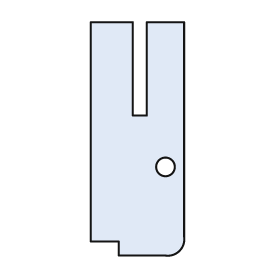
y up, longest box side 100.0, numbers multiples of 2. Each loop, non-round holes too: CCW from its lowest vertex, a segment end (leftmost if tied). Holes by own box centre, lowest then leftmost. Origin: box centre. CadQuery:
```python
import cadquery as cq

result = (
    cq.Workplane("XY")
    .moveTo(-8.0, -50.0)
    .lineTo(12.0, -50.0)
    .threePointArc((18.0, -48.0), (20.0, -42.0))
    .lineTo(20.0, 50.0)
    .lineTo(4.0, 50.0)
    .lineTo(4.0, 10.0)
    .lineTo(-2.0, 10.0)
    .lineTo(-2.0, 50.0)
    .lineTo(-20.0, 50.0)
    .lineTo(-20.0, -44.0)
    .lineTo(-8.0, -44.0)
    .close()
    .moveTo(12.0, -12.0)
    .circle(4.0)
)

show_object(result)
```